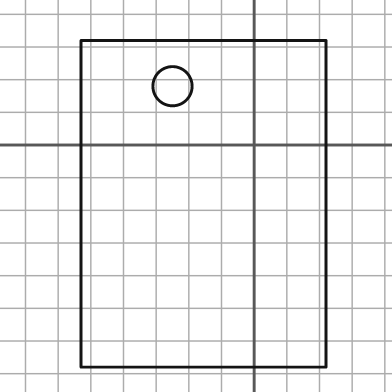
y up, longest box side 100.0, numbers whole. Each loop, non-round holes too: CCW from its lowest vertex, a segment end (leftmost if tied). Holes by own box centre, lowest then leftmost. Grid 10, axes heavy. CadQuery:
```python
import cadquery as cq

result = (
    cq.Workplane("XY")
    .moveTo(-53.0, -68.0)
    .lineTo(22.0, -68.0)
    .lineTo(22.0, 32.0)
    .lineTo(-53.0, 32.0)
    .close()
    .moveTo(-25.0, 18.0)
    .circle(6.0)
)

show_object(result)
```